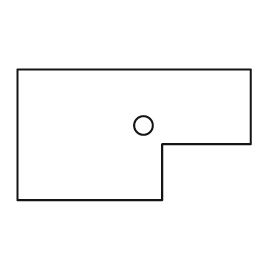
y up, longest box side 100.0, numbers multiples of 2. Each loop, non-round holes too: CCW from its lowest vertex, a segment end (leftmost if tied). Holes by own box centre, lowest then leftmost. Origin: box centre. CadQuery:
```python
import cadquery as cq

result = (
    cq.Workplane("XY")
    .moveTo(-50.0, -28.0)
    .lineTo(12.0, -28.0)
    .lineTo(12.0, -4.0)
    .lineTo(50.0, -4.0)
    .lineTo(50.0, 28.0)
    .lineTo(-50.0, 28.0)
    .close()
    .moveTo(4.0, 4.0)
    .circle(4.0)
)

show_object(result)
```